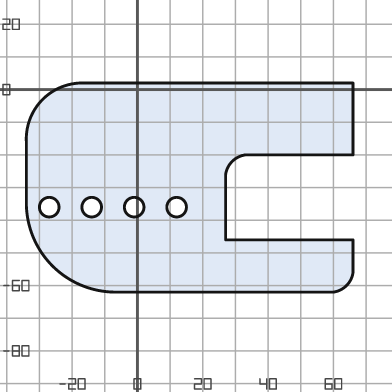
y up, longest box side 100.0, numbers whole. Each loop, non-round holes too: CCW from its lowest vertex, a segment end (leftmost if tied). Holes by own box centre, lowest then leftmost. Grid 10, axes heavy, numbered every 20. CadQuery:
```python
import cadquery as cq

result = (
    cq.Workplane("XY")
    .moveTo(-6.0, -62.0)
    .lineTo(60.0, -62.0)
    .threePointArc((64.0, -60.0), (66.0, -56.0))
    .lineTo(66.0, -46.0)
    .lineTo(27.0, -46.0)
    .lineTo(27.0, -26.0)
    .threePointArc((29.0, -22.0), (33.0, -20.0))
    .lineTo(66.0, -20.0)
    .lineTo(66.0, 2.0)
    .lineTo(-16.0, 2.0)
    .threePointArc((-29.0, -3.0), (-34.0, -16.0))
    .lineTo(-34.0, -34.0)
    .threePointArc((-26.0, -54.0), (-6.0, -62.0))
    .close()
    .moveTo(-27.0, -36.0)
    .circle(3.0)
    .moveTo(-14.0, -36.0)
    .circle(3.0)
    .moveTo(-1.0, -36.0)
    .circle(3.0)
    .moveTo(12.0, -36.0)
    .circle(3.0)
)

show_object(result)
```